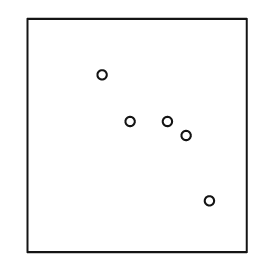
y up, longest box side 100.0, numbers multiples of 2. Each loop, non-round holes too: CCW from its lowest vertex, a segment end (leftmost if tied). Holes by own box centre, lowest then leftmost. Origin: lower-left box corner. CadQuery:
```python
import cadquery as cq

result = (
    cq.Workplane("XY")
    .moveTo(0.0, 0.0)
    .lineTo(94.0, 0.0)
    .lineTo(94.0, 100.0)
    .lineTo(0.0, 100.0)
    .close()
    .moveTo(78.0, 22.0)
    .circle(2.0)
    .moveTo(68.0, 50.0)
    .circle(2.0)
    .moveTo(44.0, 56.0)
    .circle(2.0)
    .moveTo(60.0, 56.0)
    .circle(2.0)
    .moveTo(32.0, 76.0)
    .circle(2.0)
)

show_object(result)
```